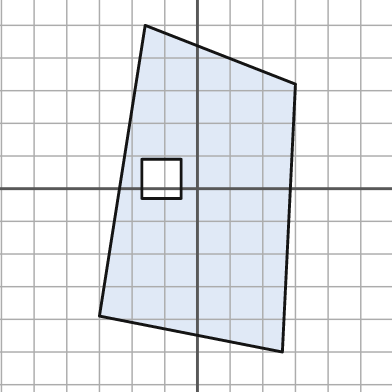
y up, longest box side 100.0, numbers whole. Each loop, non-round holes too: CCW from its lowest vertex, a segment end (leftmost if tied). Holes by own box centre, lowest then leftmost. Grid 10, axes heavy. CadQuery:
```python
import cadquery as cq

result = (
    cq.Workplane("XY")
    .moveTo(26.0, -50.0)
    .lineTo(30.0, 32.0)
    .lineTo(-16.0, 50.0)
    .lineTo(-30.0, -39.0)
    .close()
    .moveTo(-17.0, -3.0)
    .lineTo(-5.0, -3.0)
    .lineTo(-5.0, 9.0)
    .lineTo(-17.0, 9.0)
    .close()
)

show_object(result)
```